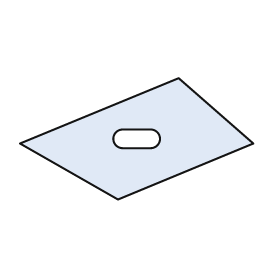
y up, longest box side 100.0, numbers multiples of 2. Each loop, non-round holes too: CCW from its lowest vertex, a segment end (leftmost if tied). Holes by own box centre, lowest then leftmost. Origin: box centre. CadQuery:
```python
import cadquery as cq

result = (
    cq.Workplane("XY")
    .moveTo(-8.0, -26.0)
    .lineTo(50.0, -2.0)
    .lineTo(18.0, 26.0)
    .lineTo(-50.0, -2.0)
    .close()
    .moveTo(-6.0, -4.0)
    .lineTo(6.0, -4.0)
    .threePointArc((10.0, 0.0), (6.0, 4.0))
    .lineTo(-6.0, 4.0)
    .threePointArc((-10.0, 0.0), (-6.0, -4.0))
    .close()
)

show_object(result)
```